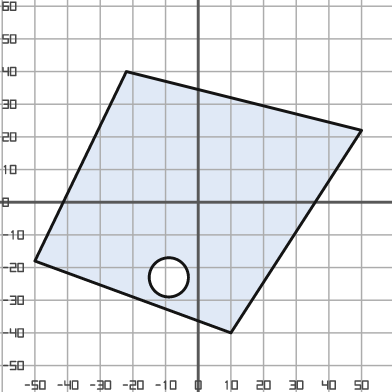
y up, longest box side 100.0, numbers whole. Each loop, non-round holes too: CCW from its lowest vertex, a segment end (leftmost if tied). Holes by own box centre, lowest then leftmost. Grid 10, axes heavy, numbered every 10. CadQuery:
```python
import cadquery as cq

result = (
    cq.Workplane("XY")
    .moveTo(10.0, -40.0)
    .lineTo(50.0, 22.0)
    .lineTo(-22.0, 40.0)
    .lineTo(-50.0, -18.0)
    .close()
    .moveTo(-9.0, -23.0)
    .circle(6.0)
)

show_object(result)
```